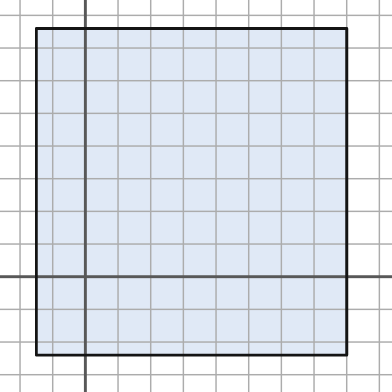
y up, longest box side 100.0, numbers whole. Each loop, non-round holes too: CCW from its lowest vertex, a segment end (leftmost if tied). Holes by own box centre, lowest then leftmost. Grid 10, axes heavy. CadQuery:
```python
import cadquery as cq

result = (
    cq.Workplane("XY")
    .moveTo(-15.0, -24.0)
    .lineTo(80.0, -24.0)
    .lineTo(80.0, 76.0)
    .lineTo(-15.0, 76.0)
    .close()
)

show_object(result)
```